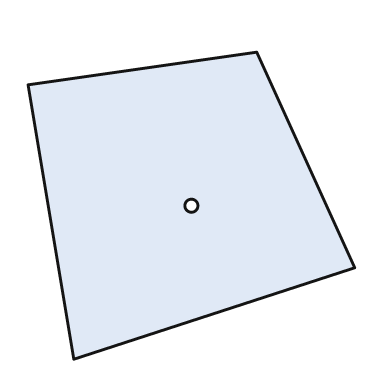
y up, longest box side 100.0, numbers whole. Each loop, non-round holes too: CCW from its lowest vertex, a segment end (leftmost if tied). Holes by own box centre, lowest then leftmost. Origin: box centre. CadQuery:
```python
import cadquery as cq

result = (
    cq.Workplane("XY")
    .moveTo(-36.0, -47.0)
    .lineTo(50.0, -19.0)
    .lineTo(20.0, 47.0)
    .lineTo(-50.0, 37.0)
    .close()
    .moveTo(0.0, 0.0)
    .circle(2.0)
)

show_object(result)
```